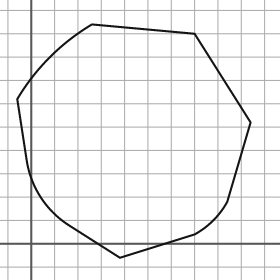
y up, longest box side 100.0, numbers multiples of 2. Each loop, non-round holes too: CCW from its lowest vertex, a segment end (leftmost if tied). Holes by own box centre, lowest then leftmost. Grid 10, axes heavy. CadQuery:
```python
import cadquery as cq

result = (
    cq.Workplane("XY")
    .moveTo(38.0, -6.0)
    .lineTo(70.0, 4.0)
    .threePointArc((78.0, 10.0), (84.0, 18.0))
    .lineTo(94.0, 52.0)
    .lineTo(70.0, 90.0)
    .lineTo(26.0, 94.0)
    .threePointArc((8.0, 80.0), (-6.0, 62.0))
    .lineTo(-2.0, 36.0)
    .threePointArc((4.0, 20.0), (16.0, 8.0))
    .close()
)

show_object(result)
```